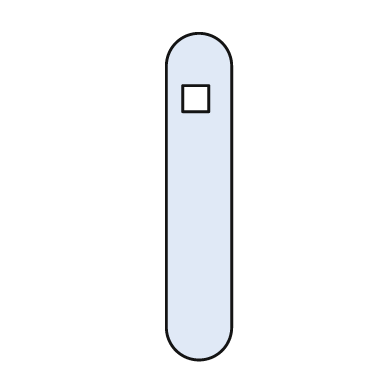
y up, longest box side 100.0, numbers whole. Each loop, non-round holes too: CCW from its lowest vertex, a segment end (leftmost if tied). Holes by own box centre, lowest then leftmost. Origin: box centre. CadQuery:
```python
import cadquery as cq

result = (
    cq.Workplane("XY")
    .moveTo(-10.0, -40.0)
    .threePointArc((0.0, -50.0), (10.0, -40.0))
    .lineTo(10.0, 40.0)
    .threePointArc((0.0, 50.0), (-10.0, 40.0))
    .close()
    .moveTo(-5.0, 26.0)
    .lineTo(3.0, 26.0)
    .lineTo(3.0, 34.0)
    .lineTo(-5.0, 34.0)
    .close()
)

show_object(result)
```